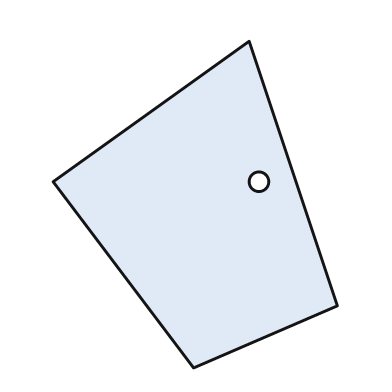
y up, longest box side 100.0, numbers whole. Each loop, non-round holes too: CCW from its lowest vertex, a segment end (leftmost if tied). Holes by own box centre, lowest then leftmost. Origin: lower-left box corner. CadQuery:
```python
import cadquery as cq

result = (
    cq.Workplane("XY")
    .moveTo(43.0, 0.0)
    .lineTo(87.0, 19.0)
    .lineTo(60.0, 100.0)
    .lineTo(0.0, 57.0)
    .close()
    .moveTo(63.0, 57.0)
    .circle(3.0)
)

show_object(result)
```